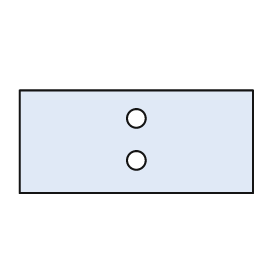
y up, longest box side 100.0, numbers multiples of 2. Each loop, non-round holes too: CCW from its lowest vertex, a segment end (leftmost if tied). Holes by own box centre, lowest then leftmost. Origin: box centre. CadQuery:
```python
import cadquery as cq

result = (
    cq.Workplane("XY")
    .moveTo(-50.0, -22.0)
    .lineTo(50.0, -22.0)
    .lineTo(50.0, 22.0)
    .lineTo(-50.0, 22.0)
    .close()
    .moveTo(0.0, -8.0)
    .circle(4.0)
    .moveTo(0.0, 10.0)
    .circle(4.0)
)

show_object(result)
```